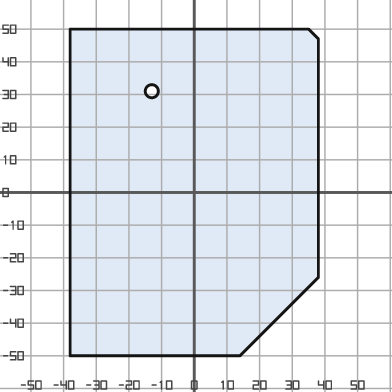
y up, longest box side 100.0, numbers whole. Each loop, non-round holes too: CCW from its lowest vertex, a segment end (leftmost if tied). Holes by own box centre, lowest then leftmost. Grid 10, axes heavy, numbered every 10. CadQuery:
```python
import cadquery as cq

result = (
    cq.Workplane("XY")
    .moveTo(-38.0, -50.0)
    .lineTo(14.0, -50.0)
    .lineTo(38.0, -26.0)
    .lineTo(38.0, 47.0)
    .lineTo(35.0, 50.0)
    .lineTo(-38.0, 50.0)
    .close()
    .moveTo(-13.0, 31.0)
    .circle(2.0)
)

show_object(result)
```